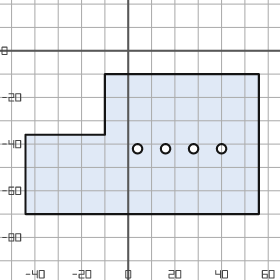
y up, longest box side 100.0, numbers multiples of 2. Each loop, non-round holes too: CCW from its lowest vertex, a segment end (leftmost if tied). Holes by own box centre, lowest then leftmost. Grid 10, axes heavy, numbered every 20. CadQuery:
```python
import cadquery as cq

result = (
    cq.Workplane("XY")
    .moveTo(-44.0, -70.0)
    .lineTo(56.0, -70.0)
    .lineTo(56.0, -10.0)
    .lineTo(-10.0, -10.0)
    .lineTo(-10.0, -36.0)
    .lineTo(-44.0, -36.0)
    .close()
    .moveTo(4.0, -42.0)
    .circle(2.0)
    .moveTo(16.0, -42.0)
    .circle(2.0)
    .moveTo(28.0, -42.0)
    .circle(2.0)
    .moveTo(40.0, -42.0)
    .circle(2.0)
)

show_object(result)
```